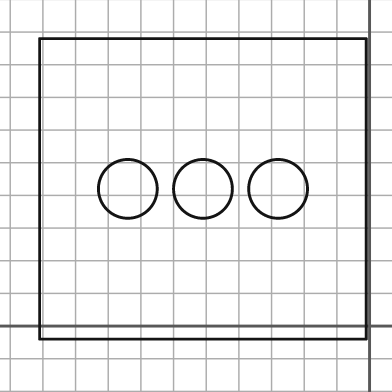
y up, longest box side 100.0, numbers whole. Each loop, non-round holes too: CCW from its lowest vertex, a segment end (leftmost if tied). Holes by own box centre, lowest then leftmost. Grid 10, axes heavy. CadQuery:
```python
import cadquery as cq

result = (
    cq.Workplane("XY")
    .moveTo(-101.0, -4.0)
    .lineTo(-1.0, -4.0)
    .lineTo(-1.0, 88.0)
    .lineTo(-101.0, 88.0)
    .close()
    .moveTo(-74.0, 42.0)
    .circle(9.0)
    .moveTo(-51.0, 42.0)
    .circle(9.0)
    .moveTo(-28.0, 42.0)
    .circle(9.0)
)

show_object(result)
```